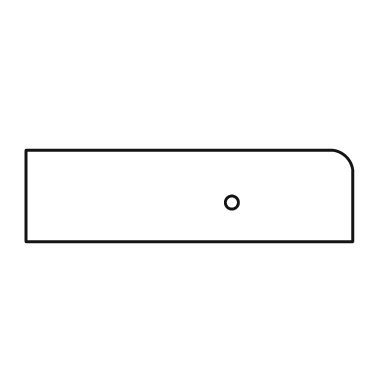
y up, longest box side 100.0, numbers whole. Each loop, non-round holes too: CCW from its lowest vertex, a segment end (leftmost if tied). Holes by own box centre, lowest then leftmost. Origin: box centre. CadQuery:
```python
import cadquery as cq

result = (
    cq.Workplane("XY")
    .moveTo(-50.0, -14.0)
    .lineTo(50.0, -14.0)
    .lineTo(50.0, 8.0)
    .threePointArc((48.0, 12.0), (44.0, 14.0))
    .lineTo(-50.0, 14.0)
    .close()
    .moveTo(13.0, -2.0)
    .circle(2.0)
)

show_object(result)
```